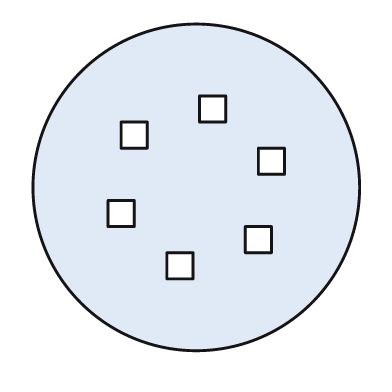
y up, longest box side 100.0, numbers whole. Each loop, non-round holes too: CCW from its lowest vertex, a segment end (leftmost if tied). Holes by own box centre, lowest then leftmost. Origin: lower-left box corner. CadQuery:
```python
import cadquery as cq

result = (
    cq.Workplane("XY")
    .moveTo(50.0, 50.0)
    .circle(50.0)
    .moveTo(41.0, 22.0)
    .lineTo(49.0, 22.0)
    .lineTo(49.0, 30.0)
    .lineTo(41.0, 30.0)
    .close()
    .moveTo(65.0, 30.0)
    .lineTo(73.0, 30.0)
    .lineTo(73.0, 38.0)
    .lineTo(65.0, 38.0)
    .close()
    .moveTo(23.0, 38.0)
    .lineTo(31.0, 38.0)
    .lineTo(31.0, 46.0)
    .lineTo(23.0, 46.0)
    .close()
    .moveTo(69.0, 54.0)
    .lineTo(77.0, 54.0)
    .lineTo(77.0, 62.0)
    .lineTo(69.0, 62.0)
    .close()
    .moveTo(27.0, 62.0)
    .lineTo(35.0, 62.0)
    .lineTo(35.0, 70.0)
    .lineTo(27.0, 70.0)
    .close()
    .moveTo(51.0, 70.0)
    .lineTo(59.0, 70.0)
    .lineTo(59.0, 78.0)
    .lineTo(51.0, 78.0)
    .close()
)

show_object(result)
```